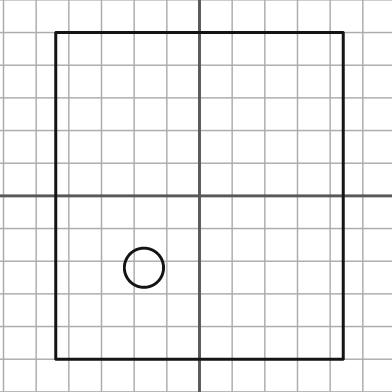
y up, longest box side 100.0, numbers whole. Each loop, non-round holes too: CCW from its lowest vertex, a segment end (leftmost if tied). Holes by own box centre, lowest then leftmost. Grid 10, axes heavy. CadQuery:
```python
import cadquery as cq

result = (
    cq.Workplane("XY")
    .moveTo(-44.0, -50.0)
    .lineTo(44.0, -50.0)
    .lineTo(44.0, 50.0)
    .lineTo(-44.0, 50.0)
    .close()
    .moveTo(-17.0, -22.0)
    .circle(6.0)
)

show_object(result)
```